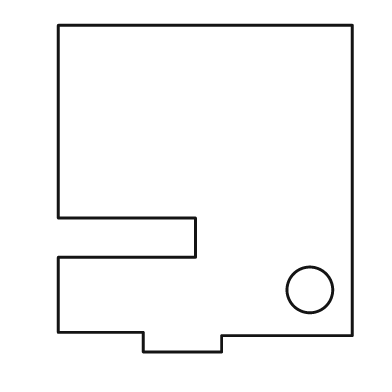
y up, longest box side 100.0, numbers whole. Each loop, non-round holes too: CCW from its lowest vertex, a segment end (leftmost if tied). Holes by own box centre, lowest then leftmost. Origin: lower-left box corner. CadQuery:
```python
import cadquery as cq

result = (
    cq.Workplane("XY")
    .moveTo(26.0, 0.0)
    .lineTo(50.0, 0.0)
    .lineTo(50.0, 5.0)
    .lineTo(90.0, 5.0)
    .lineTo(90.0, 100.0)
    .lineTo(0.0, 100.0)
    .lineTo(0.0, 41.0)
    .lineTo(42.0, 41.0)
    .lineTo(42.0, 29.0)
    .lineTo(0.0, 29.0)
    .lineTo(0.0, 6.0)
    .lineTo(26.0, 6.0)
    .close()
    .moveTo(77.0, 19.0)
    .circle(7.0)
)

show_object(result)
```